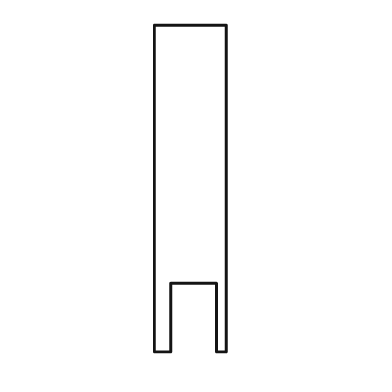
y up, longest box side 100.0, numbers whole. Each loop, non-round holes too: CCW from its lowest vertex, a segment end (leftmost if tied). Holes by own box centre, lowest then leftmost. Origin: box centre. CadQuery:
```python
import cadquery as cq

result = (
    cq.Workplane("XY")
    .moveTo(-11.0, -50.0)
    .lineTo(-6.0, -50.0)
    .lineTo(-6.0, -29.0)
    .lineTo(8.0, -29.0)
    .lineTo(8.0, -50.0)
    .lineTo(11.0, -50.0)
    .lineTo(11.0, 50.0)
    .lineTo(-11.0, 50.0)
    .close()
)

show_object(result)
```